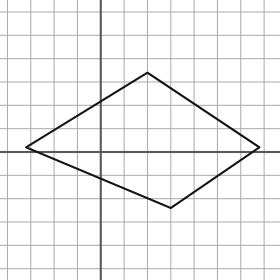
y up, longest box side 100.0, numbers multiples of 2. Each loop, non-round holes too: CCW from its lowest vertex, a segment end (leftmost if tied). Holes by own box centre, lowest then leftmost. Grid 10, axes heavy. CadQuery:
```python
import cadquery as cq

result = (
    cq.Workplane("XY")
    .moveTo(30.0, -24.0)
    .lineTo(68.0, 2.0)
    .lineTo(20.0, 34.0)
    .lineTo(-32.0, 2.0)
    .close()
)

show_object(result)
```